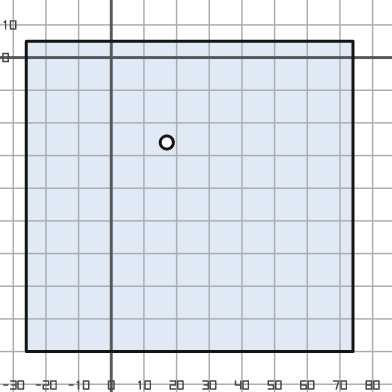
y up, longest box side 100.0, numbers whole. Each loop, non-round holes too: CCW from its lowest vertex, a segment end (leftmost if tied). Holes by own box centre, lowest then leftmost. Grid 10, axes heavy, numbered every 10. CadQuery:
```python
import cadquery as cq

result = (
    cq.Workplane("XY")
    .moveTo(-26.0, -90.0)
    .lineTo(74.0, -90.0)
    .lineTo(74.0, 5.0)
    .lineTo(-26.0, 5.0)
    .close()
    .moveTo(17.0, -26.0)
    .circle(2.0)
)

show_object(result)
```